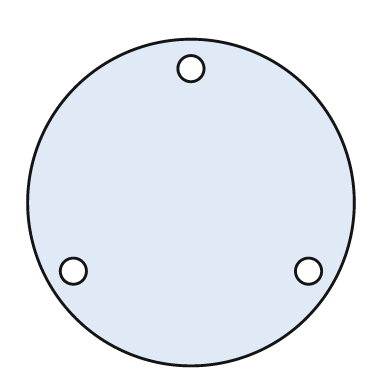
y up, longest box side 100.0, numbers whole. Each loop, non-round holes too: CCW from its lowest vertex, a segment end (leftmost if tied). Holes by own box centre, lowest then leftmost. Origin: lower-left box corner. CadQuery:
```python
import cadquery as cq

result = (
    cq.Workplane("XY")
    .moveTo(50.0, 50.0)
    .circle(50.0)
    .moveTo(14.0, 29.0)
    .circle(4.0)
    .moveTo(86.0, 29.0)
    .circle(4.0)
    .moveTo(50.0, 91.0)
    .circle(4.0)
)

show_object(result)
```